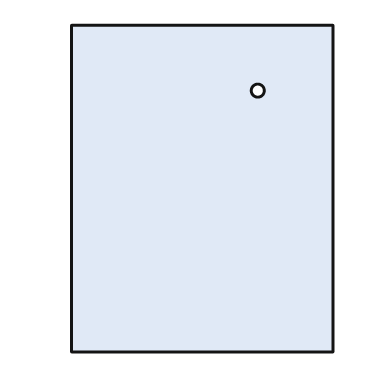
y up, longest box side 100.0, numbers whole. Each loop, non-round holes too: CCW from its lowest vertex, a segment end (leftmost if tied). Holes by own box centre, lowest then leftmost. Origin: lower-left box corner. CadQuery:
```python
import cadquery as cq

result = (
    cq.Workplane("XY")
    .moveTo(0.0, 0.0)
    .lineTo(80.0, 0.0)
    .lineTo(80.0, 100.0)
    .lineTo(0.0, 100.0)
    .close()
    .moveTo(57.0, 80.0)
    .circle(2.0)
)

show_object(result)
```